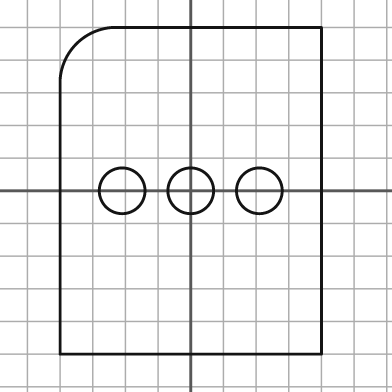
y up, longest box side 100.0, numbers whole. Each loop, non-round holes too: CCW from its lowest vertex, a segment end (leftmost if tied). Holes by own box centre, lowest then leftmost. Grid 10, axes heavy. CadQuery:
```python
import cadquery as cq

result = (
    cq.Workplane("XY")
    .moveTo(-40.0, -50.0)
    .lineTo(40.0, -50.0)
    .lineTo(40.0, 50.0)
    .lineTo(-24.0, 50.0)
    .threePointArc((-35.0, 45.0), (-40.0, 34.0))
    .close()
    .moveTo(-21.0, 0.0)
    .circle(7.0)
    .moveTo(0.0, 0.0)
    .circle(7.0)
    .moveTo(21.0, 0.0)
    .circle(7.0)
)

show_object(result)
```